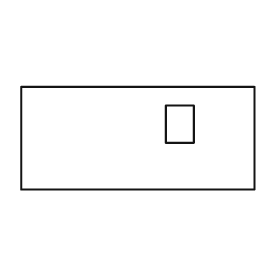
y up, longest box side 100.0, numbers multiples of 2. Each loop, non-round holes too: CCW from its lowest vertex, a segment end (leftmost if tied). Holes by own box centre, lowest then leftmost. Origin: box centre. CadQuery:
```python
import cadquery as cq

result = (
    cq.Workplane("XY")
    .moveTo(-50.0, -22.0)
    .lineTo(50.0, -22.0)
    .lineTo(50.0, 22.0)
    .lineTo(-50.0, 22.0)
    .close()
    .moveTo(12.0, -2.0)
    .lineTo(24.0, -2.0)
    .lineTo(24.0, 14.0)
    .lineTo(12.0, 14.0)
    .close()
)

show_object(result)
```